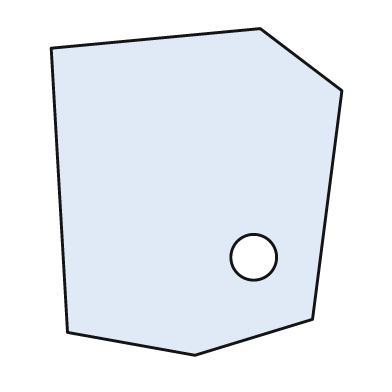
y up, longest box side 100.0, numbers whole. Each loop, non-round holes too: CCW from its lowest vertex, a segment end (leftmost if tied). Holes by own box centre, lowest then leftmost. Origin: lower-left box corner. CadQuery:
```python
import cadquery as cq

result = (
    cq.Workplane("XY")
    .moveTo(44.0, 0.0)
    .lineTo(80.0, 11.0)
    .lineTo(89.0, 81.0)
    .lineTo(64.0, 100.0)
    .lineTo(0.0, 94.0)
    .lineTo(5.0, 7.0)
    .close()
    .moveTo(62.0, 30.0)
    .circle(7.0)
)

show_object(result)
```